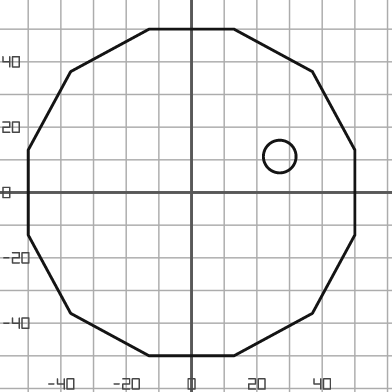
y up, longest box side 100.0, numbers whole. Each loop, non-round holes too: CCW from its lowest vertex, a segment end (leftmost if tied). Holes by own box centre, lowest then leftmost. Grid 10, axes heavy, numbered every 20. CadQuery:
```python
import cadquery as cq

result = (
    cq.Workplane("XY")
    .moveTo(-13.0, -50.0)
    .lineTo(13.0, -50.0)
    .lineTo(37.0, -37.0)
    .lineTo(50.0, -13.0)
    .lineTo(50.0, 13.0)
    .lineTo(37.0, 37.0)
    .lineTo(13.0, 50.0)
    .lineTo(-13.0, 50.0)
    .lineTo(-37.0, 37.0)
    .lineTo(-50.0, 13.0)
    .lineTo(-50.0, -13.0)
    .lineTo(-37.0, -37.0)
    .close()
    .moveTo(27.0, 11.0)
    .circle(5.0)
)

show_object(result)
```